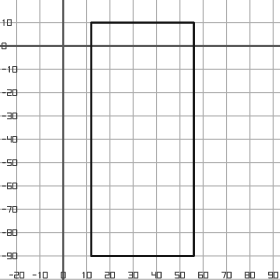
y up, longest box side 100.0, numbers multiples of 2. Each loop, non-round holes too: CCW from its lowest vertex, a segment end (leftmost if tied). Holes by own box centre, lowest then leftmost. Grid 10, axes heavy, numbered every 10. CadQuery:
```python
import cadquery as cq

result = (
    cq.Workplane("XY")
    .moveTo(12.0, -90.0)
    .lineTo(56.0, -90.0)
    .lineTo(56.0, 10.0)
    .lineTo(12.0, 10.0)
    .close()
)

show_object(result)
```